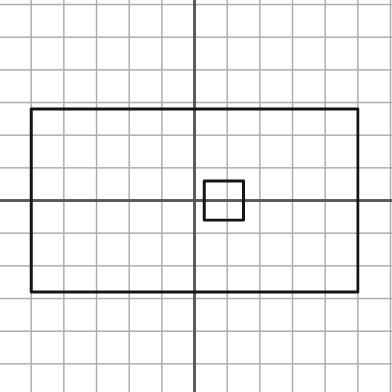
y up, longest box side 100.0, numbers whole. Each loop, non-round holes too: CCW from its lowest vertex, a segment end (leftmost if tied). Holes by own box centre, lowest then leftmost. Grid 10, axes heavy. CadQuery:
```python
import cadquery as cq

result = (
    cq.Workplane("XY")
    .moveTo(-50.0, -28.0)
    .lineTo(50.0, -28.0)
    .lineTo(50.0, 28.0)
    .lineTo(-50.0, 28.0)
    .close()
    .moveTo(3.0, -6.0)
    .lineTo(15.0, -6.0)
    .lineTo(15.0, 6.0)
    .lineTo(3.0, 6.0)
    .close()
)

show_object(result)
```